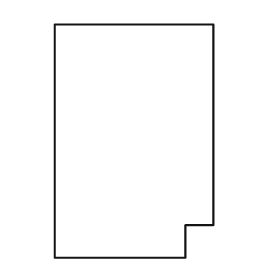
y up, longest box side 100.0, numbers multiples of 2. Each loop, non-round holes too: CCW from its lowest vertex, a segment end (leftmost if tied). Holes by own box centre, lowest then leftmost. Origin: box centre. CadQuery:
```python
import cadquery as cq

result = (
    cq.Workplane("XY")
    .moveTo(-34.0, -50.0)
    .lineTo(22.0, -50.0)
    .lineTo(22.0, -36.0)
    .lineTo(34.0, -36.0)
    .lineTo(34.0, 50.0)
    .lineTo(-34.0, 50.0)
    .close()
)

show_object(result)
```